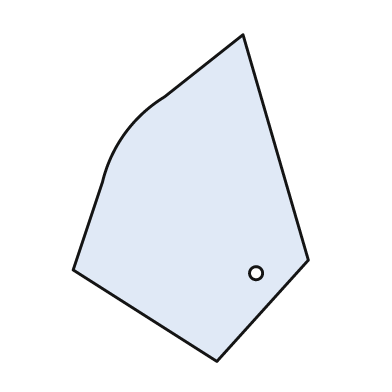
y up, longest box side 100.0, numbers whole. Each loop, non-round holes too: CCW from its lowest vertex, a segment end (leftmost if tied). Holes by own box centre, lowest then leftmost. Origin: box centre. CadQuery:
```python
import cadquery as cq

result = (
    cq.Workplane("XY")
    .moveTo(8.0, -50.0)
    .lineTo(36.0, -19.0)
    .lineTo(16.0, 50.0)
    .lineTo(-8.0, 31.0)
    .threePointArc((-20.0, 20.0), (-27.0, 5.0))
    .lineTo(-36.0, -22.0)
    .close()
    .moveTo(20.0, -23.0)
    .circle(2.0)
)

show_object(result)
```